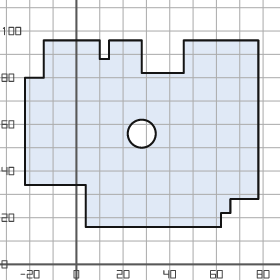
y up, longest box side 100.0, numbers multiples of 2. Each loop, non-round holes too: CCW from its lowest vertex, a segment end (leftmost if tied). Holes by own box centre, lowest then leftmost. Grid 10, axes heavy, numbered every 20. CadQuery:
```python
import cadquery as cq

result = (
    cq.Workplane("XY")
    .moveTo(4.0, 16.0)
    .lineTo(62.0, 16.0)
    .lineTo(62.0, 22.0)
    .lineTo(66.0, 22.0)
    .lineTo(66.0, 28.0)
    .lineTo(78.0, 28.0)
    .lineTo(78.0, 96.0)
    .lineTo(46.0, 96.0)
    .lineTo(46.0, 82.0)
    .lineTo(28.0, 82.0)
    .lineTo(28.0, 96.0)
    .lineTo(14.0, 96.0)
    .lineTo(14.0, 88.0)
    .lineTo(10.0, 88.0)
    .lineTo(10.0, 96.0)
    .lineTo(-14.0, 96.0)
    .lineTo(-14.0, 80.0)
    .lineTo(-22.0, 80.0)
    .lineTo(-22.0, 34.0)
    .lineTo(4.0, 34.0)
    .close()
    .moveTo(28.0, 56.0)
    .circle(6.0)
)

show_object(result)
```